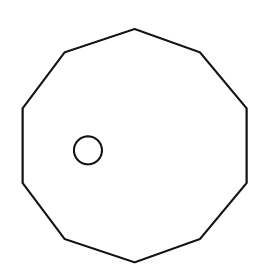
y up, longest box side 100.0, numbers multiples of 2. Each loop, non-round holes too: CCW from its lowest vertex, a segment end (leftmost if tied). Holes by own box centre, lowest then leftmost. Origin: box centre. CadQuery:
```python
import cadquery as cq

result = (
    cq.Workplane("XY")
    .moveTo(0.0, -50.0)
    .lineTo(28.0, -40.0)
    .lineTo(48.0, -16.0)
    .lineTo(48.0, 16.0)
    .lineTo(28.0, 40.0)
    .lineTo(0.0, 50.0)
    .lineTo(-30.0, 40.0)
    .lineTo(-48.0, 16.0)
    .lineTo(-48.0, -16.0)
    .lineTo(-30.0, -40.0)
    .close()
    .moveTo(-20.0, -2.0)
    .circle(6.0)
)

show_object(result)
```